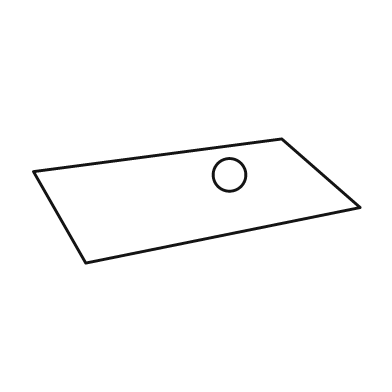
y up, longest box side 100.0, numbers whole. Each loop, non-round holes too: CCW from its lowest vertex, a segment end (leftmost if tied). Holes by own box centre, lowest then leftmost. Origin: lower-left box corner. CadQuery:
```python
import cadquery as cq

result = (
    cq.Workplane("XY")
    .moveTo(16.0, 0.0)
    .lineTo(100.0, 17.0)
    .lineTo(76.0, 38.0)
    .lineTo(0.0, 28.0)
    .close()
    .moveTo(60.0, 27.0)
    .circle(5.0)
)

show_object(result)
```